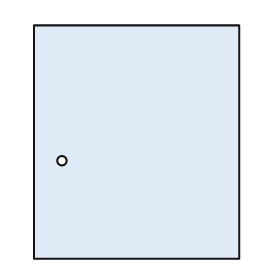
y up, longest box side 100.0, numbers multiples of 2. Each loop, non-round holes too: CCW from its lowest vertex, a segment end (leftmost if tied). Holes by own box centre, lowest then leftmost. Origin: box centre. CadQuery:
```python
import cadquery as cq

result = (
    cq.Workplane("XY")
    .moveTo(-44.0, -50.0)
    .lineTo(44.0, -50.0)
    .lineTo(44.0, 50.0)
    .lineTo(-44.0, 50.0)
    .close()
    .moveTo(-32.0, -8.0)
    .circle(2.0)
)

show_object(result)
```